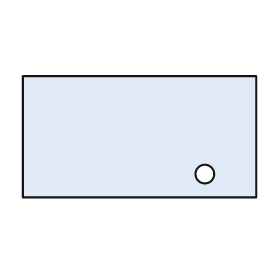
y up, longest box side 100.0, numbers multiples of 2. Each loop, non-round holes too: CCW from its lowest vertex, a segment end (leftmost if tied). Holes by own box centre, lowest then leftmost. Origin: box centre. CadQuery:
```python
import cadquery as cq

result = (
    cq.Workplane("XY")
    .moveTo(-50.0, -26.0)
    .lineTo(50.0, -26.0)
    .lineTo(50.0, 26.0)
    .lineTo(-50.0, 26.0)
    .close()
    .moveTo(28.0, -16.0)
    .circle(4.0)
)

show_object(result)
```